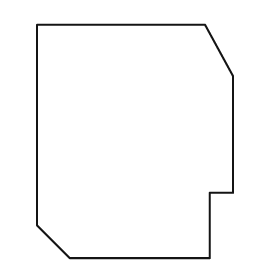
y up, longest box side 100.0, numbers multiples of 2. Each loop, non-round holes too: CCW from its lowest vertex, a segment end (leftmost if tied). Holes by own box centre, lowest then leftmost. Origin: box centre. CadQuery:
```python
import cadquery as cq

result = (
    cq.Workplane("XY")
    .moveTo(-28.0, -50.0)
    .lineTo(32.0, -50.0)
    .lineTo(32.0, -22.0)
    .lineTo(42.0, -22.0)
    .lineTo(42.0, 28.0)
    .lineTo(30.0, 50.0)
    .lineTo(-42.0, 50.0)
    .lineTo(-42.0, -36.0)
    .close()
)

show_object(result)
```